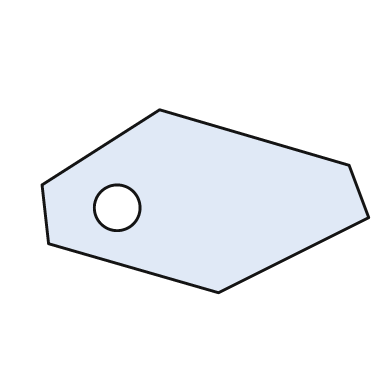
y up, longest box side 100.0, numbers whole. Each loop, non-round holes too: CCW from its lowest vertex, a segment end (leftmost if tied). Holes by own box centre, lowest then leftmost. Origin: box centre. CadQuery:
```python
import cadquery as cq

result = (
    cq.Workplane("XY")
    .moveTo(4.0, -28.0)
    .lineTo(50.0, -5.0)
    .lineTo(44.0, 11.0)
    .lineTo(-14.0, 28.0)
    .lineTo(-50.0, 5.0)
    .lineTo(-48.0, -13.0)
    .close()
    .moveTo(-27.0, -2.0)
    .circle(7.0)
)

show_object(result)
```